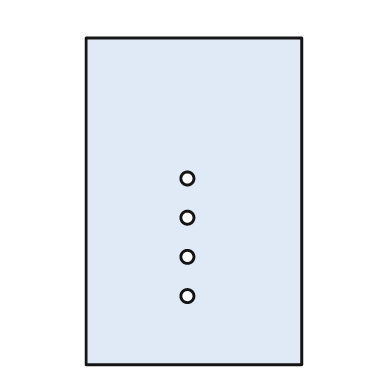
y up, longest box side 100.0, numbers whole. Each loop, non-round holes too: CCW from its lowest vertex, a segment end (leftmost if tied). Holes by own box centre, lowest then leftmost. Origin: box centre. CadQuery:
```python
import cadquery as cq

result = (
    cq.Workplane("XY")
    .moveTo(-33.0, -50.0)
    .lineTo(33.0, -50.0)
    .lineTo(33.0, 50.0)
    .lineTo(-33.0, 50.0)
    .close()
    .moveTo(-2.0, -29.0)
    .circle(2.0)
    .moveTo(-2.0, -17.0)
    .circle(2.0)
    .moveTo(-2.0, -5.0)
    .circle(2.0)
    .moveTo(-2.0, 7.0)
    .circle(2.0)
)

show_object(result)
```